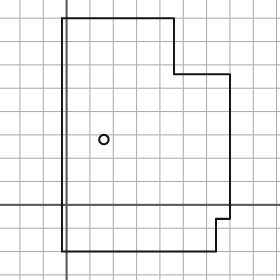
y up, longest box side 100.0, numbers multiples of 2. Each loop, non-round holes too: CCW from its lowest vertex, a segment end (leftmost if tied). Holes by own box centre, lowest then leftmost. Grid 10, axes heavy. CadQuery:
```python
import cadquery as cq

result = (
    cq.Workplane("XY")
    .moveTo(-2.0, -20.0)
    .lineTo(64.0, -20.0)
    .lineTo(64.0, -6.0)
    .lineTo(70.0, -6.0)
    .lineTo(70.0, 56.0)
    .lineTo(46.0, 56.0)
    .lineTo(46.0, 80.0)
    .lineTo(-2.0, 80.0)
    .close()
    .moveTo(16.0, 28.0)
    .circle(2.0)
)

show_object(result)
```